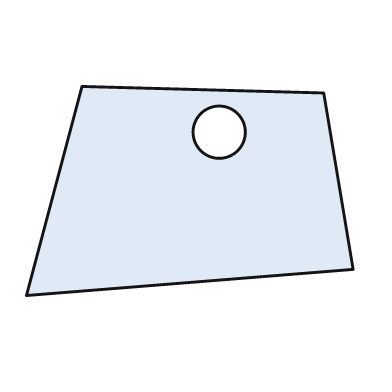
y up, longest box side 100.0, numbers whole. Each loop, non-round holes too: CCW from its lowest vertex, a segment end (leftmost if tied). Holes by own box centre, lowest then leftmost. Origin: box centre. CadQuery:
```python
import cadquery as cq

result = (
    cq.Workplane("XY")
    .moveTo(-50.0, -32.0)
    .lineTo(50.0, -24.0)
    .lineTo(41.0, 30.0)
    .lineTo(-33.0, 32.0)
    .close()
    .moveTo(9.0, 18.0)
    .circle(8.0)
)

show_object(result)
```